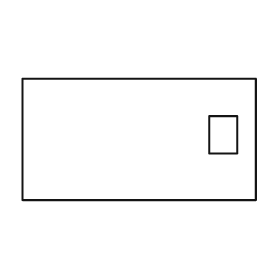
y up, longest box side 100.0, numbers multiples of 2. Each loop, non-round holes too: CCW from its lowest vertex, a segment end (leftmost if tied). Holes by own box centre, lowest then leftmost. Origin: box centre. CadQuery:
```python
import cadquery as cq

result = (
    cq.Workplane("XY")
    .moveTo(-50.0, -26.0)
    .lineTo(50.0, -26.0)
    .lineTo(50.0, 26.0)
    .lineTo(-50.0, 26.0)
    .close()
    .moveTo(30.0, -6.0)
    .lineTo(42.0, -6.0)
    .lineTo(42.0, 10.0)
    .lineTo(30.0, 10.0)
    .close()
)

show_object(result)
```